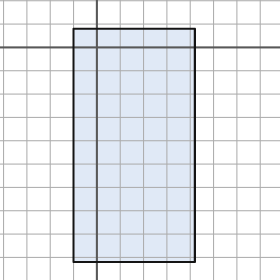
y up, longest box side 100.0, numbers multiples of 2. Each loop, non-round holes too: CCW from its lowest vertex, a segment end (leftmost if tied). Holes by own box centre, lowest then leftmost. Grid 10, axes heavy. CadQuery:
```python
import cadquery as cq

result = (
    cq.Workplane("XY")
    .moveTo(-10.0, -92.0)
    .lineTo(42.0, -92.0)
    .lineTo(42.0, 8.0)
    .lineTo(-10.0, 8.0)
    .close()
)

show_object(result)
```